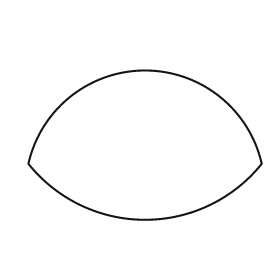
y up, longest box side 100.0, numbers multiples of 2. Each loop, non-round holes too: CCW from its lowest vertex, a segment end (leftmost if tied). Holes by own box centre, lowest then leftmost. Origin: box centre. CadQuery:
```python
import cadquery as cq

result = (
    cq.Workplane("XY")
    .moveTo(-50.0, -8.0)
    .threePointArc((0.0, -32.0), (50.0, -8.0))
    .threePointArc((0.0, 32.0), (-50.0, -8.0))
    .close()
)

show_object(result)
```